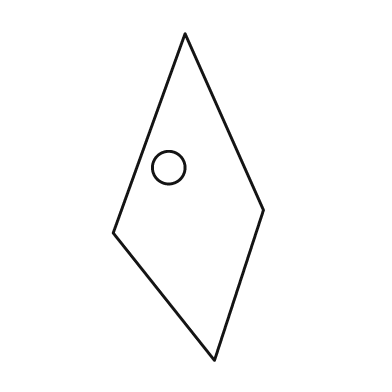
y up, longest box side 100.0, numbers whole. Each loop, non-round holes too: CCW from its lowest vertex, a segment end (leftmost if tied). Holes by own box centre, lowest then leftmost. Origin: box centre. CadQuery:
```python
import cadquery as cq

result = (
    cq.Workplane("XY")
    .moveTo(8.0, -50.0)
    .lineTo(23.0, -4.0)
    .lineTo(-1.0, 50.0)
    .lineTo(-23.0, -11.0)
    .close()
    .moveTo(-6.0, 9.0)
    .circle(5.0)
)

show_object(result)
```